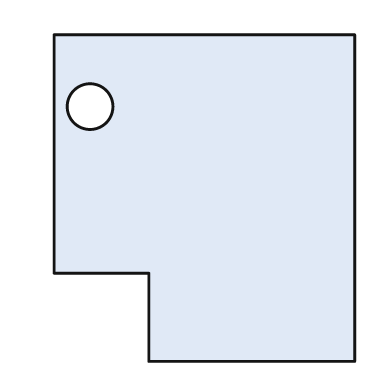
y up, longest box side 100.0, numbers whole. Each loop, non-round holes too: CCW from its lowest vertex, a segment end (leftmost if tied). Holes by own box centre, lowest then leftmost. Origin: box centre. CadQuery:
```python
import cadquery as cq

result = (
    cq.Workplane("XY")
    .moveTo(-17.0, -50.0)
    .lineTo(46.0, -50.0)
    .lineTo(46.0, 50.0)
    .lineTo(-46.0, 50.0)
    .lineTo(-46.0, -23.0)
    .lineTo(-17.0, -23.0)
    .close()
    .moveTo(-35.0, 28.0)
    .circle(7.0)
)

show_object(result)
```